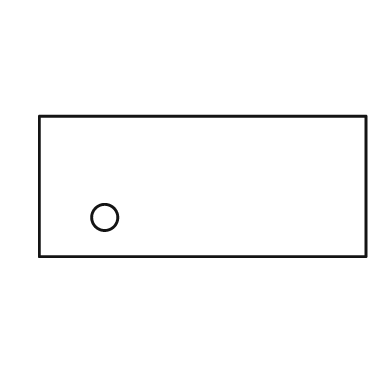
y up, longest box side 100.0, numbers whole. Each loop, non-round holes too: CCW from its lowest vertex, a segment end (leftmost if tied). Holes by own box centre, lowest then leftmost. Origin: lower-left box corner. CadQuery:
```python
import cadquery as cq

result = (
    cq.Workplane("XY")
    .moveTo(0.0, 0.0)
    .lineTo(100.0, 0.0)
    .lineTo(100.0, 43.0)
    .lineTo(0.0, 43.0)
    .close()
    .moveTo(20.0, 12.0)
    .circle(4.0)
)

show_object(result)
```